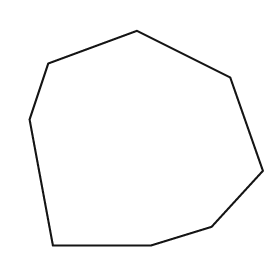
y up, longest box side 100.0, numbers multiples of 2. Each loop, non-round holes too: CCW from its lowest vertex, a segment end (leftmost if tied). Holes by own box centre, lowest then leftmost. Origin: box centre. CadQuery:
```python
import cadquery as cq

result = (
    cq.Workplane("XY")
    .moveTo(-40.0, -46.0)
    .lineTo(2.0, -46.0)
    .lineTo(28.0, -38.0)
    .lineTo(50.0, -14.0)
    .lineTo(36.0, 26.0)
    .lineTo(-4.0, 46.0)
    .lineTo(-42.0, 32.0)
    .lineTo(-50.0, 8.0)
    .close()
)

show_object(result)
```